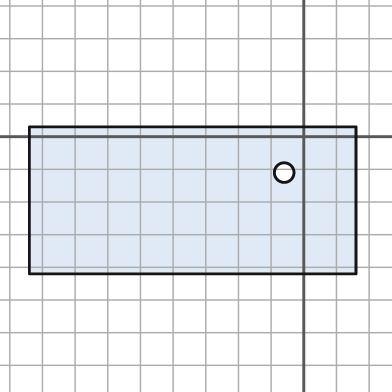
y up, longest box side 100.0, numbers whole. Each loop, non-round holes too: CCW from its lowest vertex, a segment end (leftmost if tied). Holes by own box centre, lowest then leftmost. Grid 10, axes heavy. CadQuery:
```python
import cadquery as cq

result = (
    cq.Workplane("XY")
    .moveTo(-84.0, -42.0)
    .lineTo(16.0, -42.0)
    .lineTo(16.0, 3.0)
    .lineTo(-84.0, 3.0)
    .close()
    .moveTo(-6.0, -11.0)
    .circle(3.0)
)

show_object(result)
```